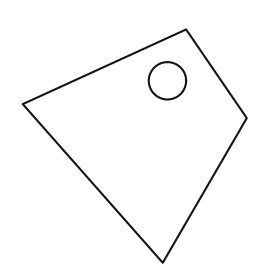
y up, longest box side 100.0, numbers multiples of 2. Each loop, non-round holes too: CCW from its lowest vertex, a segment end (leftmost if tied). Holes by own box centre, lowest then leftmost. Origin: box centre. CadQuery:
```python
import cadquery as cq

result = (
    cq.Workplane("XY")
    .moveTo(12.0, -50.0)
    .lineTo(48.0, 12.0)
    .lineTo(22.0, 50.0)
    .lineTo(-48.0, 18.0)
    .close()
    .moveTo(14.0, 28.0)
    .circle(8.0)
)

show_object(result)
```